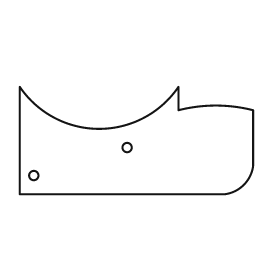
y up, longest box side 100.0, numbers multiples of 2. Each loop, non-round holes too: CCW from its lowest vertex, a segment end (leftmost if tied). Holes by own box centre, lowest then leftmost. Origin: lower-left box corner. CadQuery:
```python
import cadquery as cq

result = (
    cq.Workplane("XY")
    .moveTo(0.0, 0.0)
    .lineTo(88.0, 0.0)
    .threePointArc((96.0, 4.0), (100.0, 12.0))
    .lineTo(100.0, 36.0)
    .threePointArc((84.0, 38.0), (68.0, 36.0))
    .lineTo(68.0, 46.0)
    .threePointArc((34.0, 28.0), (0.0, 46.0))
    .close()
    .moveTo(6.0, 8.0)
    .circle(2.0)
    .moveTo(46.0, 20.0)
    .circle(2.0)
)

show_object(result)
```